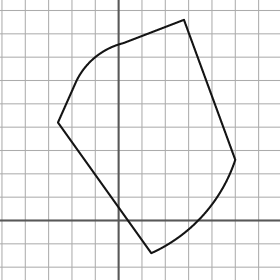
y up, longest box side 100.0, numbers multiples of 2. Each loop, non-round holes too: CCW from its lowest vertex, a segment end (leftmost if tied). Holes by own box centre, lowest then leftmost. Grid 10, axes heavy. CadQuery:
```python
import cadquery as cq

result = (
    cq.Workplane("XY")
    .moveTo(14.0, -14.0)
    .threePointArc((36.0, 2.0), (50.0, 26.0))
    .lineTo(28.0, 86.0)
    .lineTo(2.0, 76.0)
    .threePointArc((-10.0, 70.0), (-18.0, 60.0))
    .lineTo(-26.0, 42.0)
    .close()
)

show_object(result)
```